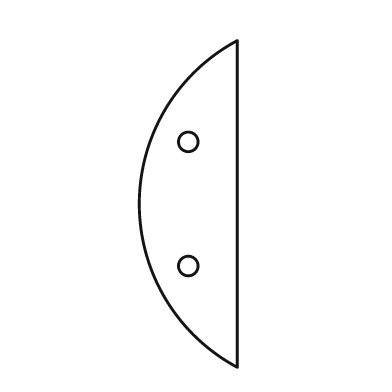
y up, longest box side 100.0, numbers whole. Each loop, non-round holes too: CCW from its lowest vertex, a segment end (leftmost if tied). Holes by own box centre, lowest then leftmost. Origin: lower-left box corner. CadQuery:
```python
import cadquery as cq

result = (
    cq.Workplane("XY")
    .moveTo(30.0, 0.0)
    .lineTo(30.0, 100.0)
    .threePointArc((0.0, 50.0), (30.0, 0.0))
    .close()
    .moveTo(15.0, 31.0)
    .circle(3.0)
    .moveTo(15.0, 69.0)
    .circle(3.0)
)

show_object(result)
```